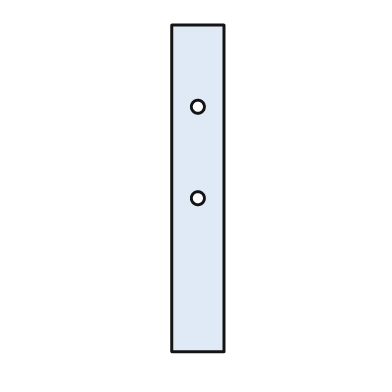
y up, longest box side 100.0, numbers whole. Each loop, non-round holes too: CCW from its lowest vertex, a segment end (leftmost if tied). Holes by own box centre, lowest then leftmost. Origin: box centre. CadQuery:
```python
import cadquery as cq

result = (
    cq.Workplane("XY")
    .moveTo(-8.0, -50.0)
    .lineTo(8.0, -50.0)
    .lineTo(8.0, 50.0)
    .lineTo(-8.0, 50.0)
    .close()
    .moveTo(0.0, -3.0)
    .circle(2.0)
    .moveTo(0.0, 25.0)
    .circle(2.0)
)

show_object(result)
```